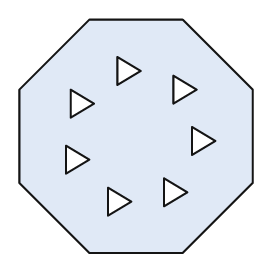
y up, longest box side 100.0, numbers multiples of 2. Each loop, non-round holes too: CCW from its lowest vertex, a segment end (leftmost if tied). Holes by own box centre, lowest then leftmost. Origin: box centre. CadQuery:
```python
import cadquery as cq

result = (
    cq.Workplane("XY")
    .moveTo(-20.0, -50.0)
    .lineTo(20.0, -50.0)
    .lineTo(50.0, -20.0)
    .lineTo(50.0, 20.0)
    .lineTo(20.0, 50.0)
    .lineTo(-20.0, 50.0)
    .lineTo(-50.0, 20.0)
    .lineTo(-50.0, -20.0)
    .close()
    .moveTo(-12.0, -34.0)
    .lineTo(-2.0, -28.0)
    .lineTo(-12.0, -22.0)
    .close()
    .moveTo(12.0, -30.0)
    .lineTo(22.0, -24.0)
    .lineTo(12.0, -18.0)
    .close()
    .moveTo(-30.0, -16.0)
    .lineTo(-20.0, -10.0)
    .lineTo(-30.0, -4.0)
    .close()
    .moveTo(24.0, -8.0)
    .lineTo(34.0, -2.0)
    .lineTo(24.0, 4.0)
    .close()
    .moveTo(-28.0, 8.0)
    .lineTo(-18.0, 14.0)
    .lineTo(-28.0, 20.0)
    .close()
    .moveTo(16.0, 14.0)
    .lineTo(26.0, 20.0)
    .lineTo(16.0, 26.0)
    .close()
    .moveTo(-8.0, 22.0)
    .lineTo(2.0, 28.0)
    .lineTo(-8.0, 34.0)
    .close()
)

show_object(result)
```